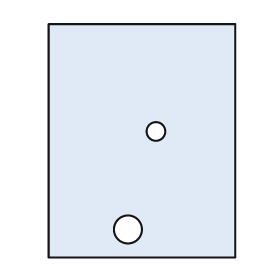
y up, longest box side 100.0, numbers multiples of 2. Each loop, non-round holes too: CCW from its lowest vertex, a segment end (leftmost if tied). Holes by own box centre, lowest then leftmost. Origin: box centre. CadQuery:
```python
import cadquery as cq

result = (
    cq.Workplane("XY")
    .moveTo(-40.0, -50.0)
    .lineTo(40.0, -50.0)
    .lineTo(40.0, 50.0)
    .lineTo(-40.0, 50.0)
    .close()
    .moveTo(-6.0, -38.0)
    .circle(6.0)
    .moveTo(6.0, 4.0)
    .circle(4.0)
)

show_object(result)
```